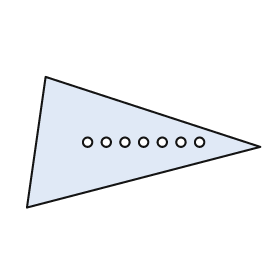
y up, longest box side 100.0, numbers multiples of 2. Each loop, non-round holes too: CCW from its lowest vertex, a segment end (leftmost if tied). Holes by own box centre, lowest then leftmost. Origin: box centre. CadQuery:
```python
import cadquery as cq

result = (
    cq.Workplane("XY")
    .moveTo(-50.0, -28.0)
    .lineTo(50.0, -2.0)
    .lineTo(-42.0, 28.0)
    .close()
    .moveTo(-24.0, 0.0)
    .circle(2.0)
    .moveTo(-16.0, 0.0)
    .circle(2.0)
    .moveTo(-8.0, 0.0)
    .circle(2.0)
    .moveTo(0.0, 0.0)
    .circle(2.0)
    .moveTo(8.0, 0.0)
    .circle(2.0)
    .moveTo(16.0, 0.0)
    .circle(2.0)
    .moveTo(24.0, 0.0)
    .circle(2.0)
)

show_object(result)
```